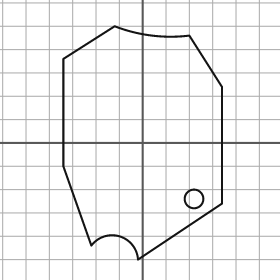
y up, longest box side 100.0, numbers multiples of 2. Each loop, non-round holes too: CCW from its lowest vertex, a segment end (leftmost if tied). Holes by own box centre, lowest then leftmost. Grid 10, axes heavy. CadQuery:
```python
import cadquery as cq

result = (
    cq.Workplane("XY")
    .moveTo(-2.0, -50.0)
    .lineTo(34.0, -26.0)
    .lineTo(34.0, 24.0)
    .lineTo(20.0, 46.0)
    .threePointArc((4.0, 46.0), (-12.0, 50.0))
    .lineTo(-34.0, 36.0)
    .lineTo(-34.0, -10.0)
    .lineTo(-22.0, -44.0)
    .threePointArc((-10.0, -40.0), (-2.0, -50.0))
    .close()
    .moveTo(22.0, -24.0)
    .circle(4.0)
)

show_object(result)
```